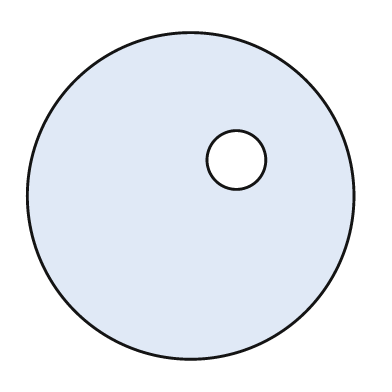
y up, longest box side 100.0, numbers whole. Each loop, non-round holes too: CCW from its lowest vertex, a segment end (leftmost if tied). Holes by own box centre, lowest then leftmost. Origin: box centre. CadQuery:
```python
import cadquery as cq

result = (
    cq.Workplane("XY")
    .moveTo(0.0, 0.0)
    .circle(50.0)
    .moveTo(14.0, 11.0)
    .circle(9.0)
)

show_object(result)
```